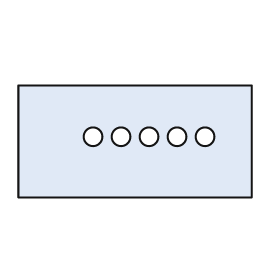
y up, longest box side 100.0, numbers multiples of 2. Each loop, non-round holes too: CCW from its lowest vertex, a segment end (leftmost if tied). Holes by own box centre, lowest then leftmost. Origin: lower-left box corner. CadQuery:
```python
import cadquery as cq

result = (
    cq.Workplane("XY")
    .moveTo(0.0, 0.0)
    .lineTo(100.0, 0.0)
    .lineTo(100.0, 48.0)
    .lineTo(0.0, 48.0)
    .close()
    .moveTo(32.0, 26.0)
    .circle(4.0)
    .moveTo(44.0, 26.0)
    .circle(4.0)
    .moveTo(56.0, 26.0)
    .circle(4.0)
    .moveTo(68.0, 26.0)
    .circle(4.0)
    .moveTo(80.0, 26.0)
    .circle(4.0)
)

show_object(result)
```